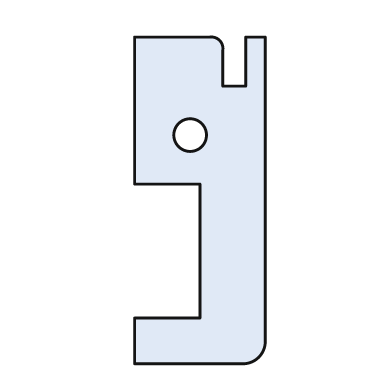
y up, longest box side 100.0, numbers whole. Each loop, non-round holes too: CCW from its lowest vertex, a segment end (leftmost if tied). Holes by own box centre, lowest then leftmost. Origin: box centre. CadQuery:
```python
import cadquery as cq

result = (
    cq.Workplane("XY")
    .moveTo(-20.0, -50.0)
    .lineTo(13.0, -50.0)
    .threePointArc((18.0, -48.0), (20.0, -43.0))
    .lineTo(20.0, 50.0)
    .lineTo(14.0, 50.0)
    .lineTo(14.0, 35.0)
    .lineTo(7.0, 35.0)
    .lineTo(7.0, 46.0)
    .threePointArc((6.0, 49.0), (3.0, 50.0))
    .lineTo(-20.0, 50.0)
    .lineTo(-20.0, 5.0)
    .lineTo(0.0, 5.0)
    .lineTo(0.0, -36.0)
    .lineTo(-20.0, -36.0)
    .close()
    .moveTo(-3.0, 20.0)
    .circle(5.0)
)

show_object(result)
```